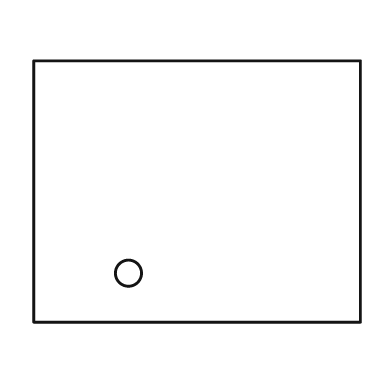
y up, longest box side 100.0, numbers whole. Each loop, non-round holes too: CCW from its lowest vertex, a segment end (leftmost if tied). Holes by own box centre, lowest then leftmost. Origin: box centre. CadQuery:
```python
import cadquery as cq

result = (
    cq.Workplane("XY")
    .moveTo(-50.0, -40.0)
    .lineTo(50.0, -40.0)
    .lineTo(50.0, 40.0)
    .lineTo(-50.0, 40.0)
    .close()
    .moveTo(-21.0, -25.0)
    .circle(4.0)
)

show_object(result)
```